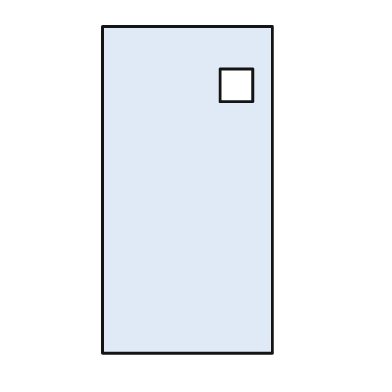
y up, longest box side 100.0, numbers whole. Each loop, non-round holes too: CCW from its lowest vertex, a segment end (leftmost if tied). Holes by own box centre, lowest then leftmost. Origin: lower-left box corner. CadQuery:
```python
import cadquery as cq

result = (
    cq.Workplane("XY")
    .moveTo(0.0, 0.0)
    .lineTo(52.0, 0.0)
    .lineTo(52.0, 100.0)
    .lineTo(0.0, 100.0)
    .close()
    .moveTo(36.0, 77.0)
    .lineTo(46.0, 77.0)
    .lineTo(46.0, 87.0)
    .lineTo(36.0, 87.0)
    .close()
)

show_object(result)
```